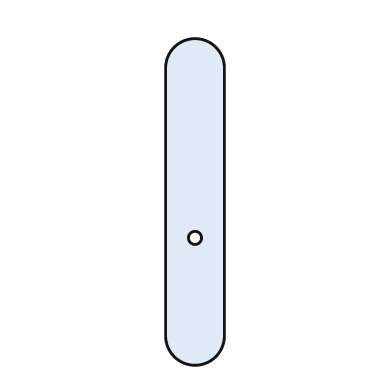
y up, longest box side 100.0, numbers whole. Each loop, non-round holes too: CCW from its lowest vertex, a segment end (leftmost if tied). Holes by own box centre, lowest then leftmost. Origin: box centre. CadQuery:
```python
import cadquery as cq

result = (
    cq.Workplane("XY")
    .moveTo(-9.0, -41.0)
    .threePointArc((0.0, -50.0), (9.0, -41.0))
    .lineTo(9.0, 41.0)
    .threePointArc((0.0, 50.0), (-9.0, 41.0))
    .close()
    .moveTo(0.0, -11.0)
    .circle(2.0)
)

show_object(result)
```